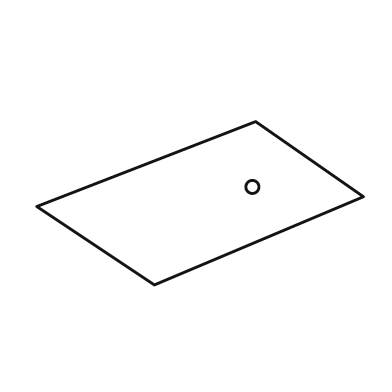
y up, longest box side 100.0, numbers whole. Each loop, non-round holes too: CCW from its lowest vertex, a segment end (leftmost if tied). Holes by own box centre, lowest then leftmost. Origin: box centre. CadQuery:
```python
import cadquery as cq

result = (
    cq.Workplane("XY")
    .moveTo(-14.0, -25.0)
    .lineTo(50.0, 2.0)
    .lineTo(17.0, 25.0)
    .lineTo(-50.0, -1.0)
    .close()
    .moveTo(16.0, 5.0)
    .circle(2.0)
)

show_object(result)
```